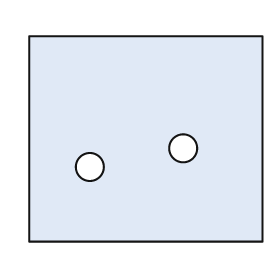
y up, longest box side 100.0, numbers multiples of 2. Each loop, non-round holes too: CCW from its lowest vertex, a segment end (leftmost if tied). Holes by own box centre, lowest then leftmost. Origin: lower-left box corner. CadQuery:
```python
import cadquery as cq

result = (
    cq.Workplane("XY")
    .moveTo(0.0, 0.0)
    .lineTo(100.0, 0.0)
    .lineTo(100.0, 88.0)
    .lineTo(0.0, 88.0)
    .close()
    .moveTo(26.0, 32.0)
    .circle(6.0)
    .moveTo(66.0, 40.0)
    .circle(6.0)
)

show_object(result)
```